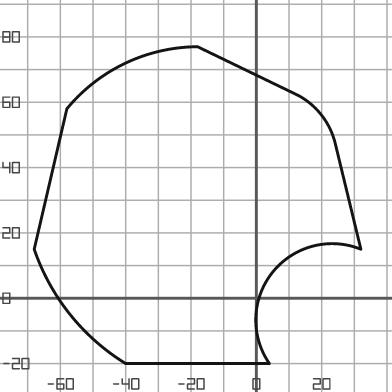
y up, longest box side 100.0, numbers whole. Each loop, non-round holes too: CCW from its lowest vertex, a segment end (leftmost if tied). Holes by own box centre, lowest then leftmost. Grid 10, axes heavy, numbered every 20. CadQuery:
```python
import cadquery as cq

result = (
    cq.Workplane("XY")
    .moveTo(-40.0, -20.0)
    .lineTo(4.0, -20.0)
    .threePointArc((5.0, 8.0), (32.0, 15.0))
    .lineTo(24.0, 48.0)
    .threePointArc((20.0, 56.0), (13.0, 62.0))
    .lineTo(-18.0, 77.0)
    .threePointArc((-40.0, 72.0), (-58.0, 58.0))
    .lineTo(-68.0, 15.0)
    .threePointArc((-57.0, -5.0), (-40.0, -20.0))
    .close()
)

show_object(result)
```